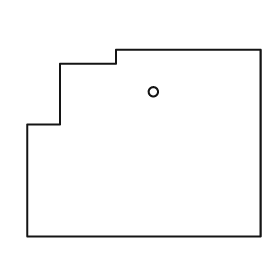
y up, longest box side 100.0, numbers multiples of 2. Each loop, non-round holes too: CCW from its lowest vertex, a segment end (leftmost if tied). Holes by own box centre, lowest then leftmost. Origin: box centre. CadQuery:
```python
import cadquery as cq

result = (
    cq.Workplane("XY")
    .moveTo(-50.0, -40.0)
    .lineTo(50.0, -40.0)
    .lineTo(50.0, 40.0)
    .lineTo(-12.0, 40.0)
    .lineTo(-12.0, 34.0)
    .lineTo(-36.0, 34.0)
    .lineTo(-36.0, 8.0)
    .lineTo(-50.0, 8.0)
    .close()
    .moveTo(4.0, 22.0)
    .circle(2.0)
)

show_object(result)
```